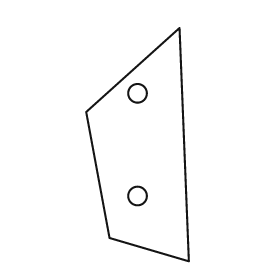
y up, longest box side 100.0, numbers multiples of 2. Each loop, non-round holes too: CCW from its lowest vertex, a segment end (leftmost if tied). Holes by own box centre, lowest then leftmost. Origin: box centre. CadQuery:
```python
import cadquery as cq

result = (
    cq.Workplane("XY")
    .moveTo(22.0, -50.0)
    .lineTo(18.0, 50.0)
    .lineTo(-22.0, 14.0)
    .lineTo(-12.0, -40.0)
    .close()
    .moveTo(0.0, -22.0)
    .circle(4.0)
    .moveTo(0.0, 22.0)
    .circle(4.0)
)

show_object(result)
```